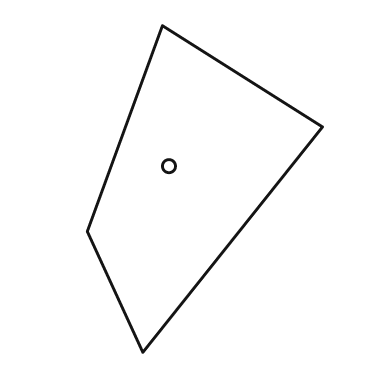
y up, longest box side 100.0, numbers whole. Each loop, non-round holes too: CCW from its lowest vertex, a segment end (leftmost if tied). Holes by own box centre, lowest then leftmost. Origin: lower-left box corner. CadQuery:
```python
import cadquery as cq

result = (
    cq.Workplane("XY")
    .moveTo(17.0, 0.0)
    .lineTo(72.0, 69.0)
    .lineTo(23.0, 100.0)
    .lineTo(0.0, 37.0)
    .close()
    .moveTo(25.0, 57.0)
    .circle(2.0)
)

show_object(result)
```